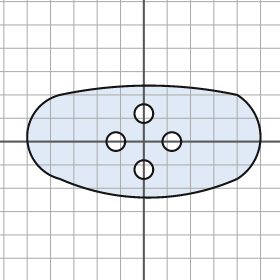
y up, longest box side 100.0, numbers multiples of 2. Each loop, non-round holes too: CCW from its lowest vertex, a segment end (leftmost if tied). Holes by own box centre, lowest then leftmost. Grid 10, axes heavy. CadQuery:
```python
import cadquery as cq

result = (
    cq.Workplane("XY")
    .moveTo(-36.0, -16.0)
    .threePointArc((2.0, -24.0), (40.0, -16.0))
    .threePointArc((50.0, 2.0), (40.0, 20.0))
    .threePointArc((2.0, 24.0), (-36.0, 20.0))
    .threePointArc((-50.0, 2.0), (-36.0, -16.0))
    .close()
    .moveTo(0.0, -12.0)
    .circle(4.0)
    .moveTo(-12.0, 0.0)
    .circle(4.0)
    .moveTo(12.0, 0.0)
    .circle(4.0)
    .moveTo(0.0, 12.0)
    .circle(4.0)
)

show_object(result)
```